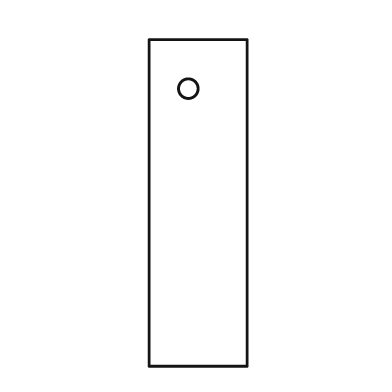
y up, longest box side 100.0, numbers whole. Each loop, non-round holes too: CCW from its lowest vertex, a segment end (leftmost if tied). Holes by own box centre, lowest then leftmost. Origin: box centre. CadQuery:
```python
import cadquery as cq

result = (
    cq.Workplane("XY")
    .moveTo(-15.0, -50.0)
    .lineTo(15.0, -50.0)
    .lineTo(15.0, 50.0)
    .lineTo(-15.0, 50.0)
    .close()
    .moveTo(-3.0, 35.0)
    .circle(3.0)
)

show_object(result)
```